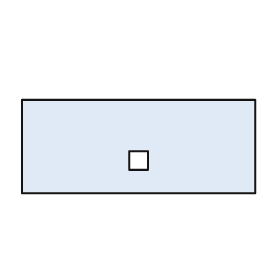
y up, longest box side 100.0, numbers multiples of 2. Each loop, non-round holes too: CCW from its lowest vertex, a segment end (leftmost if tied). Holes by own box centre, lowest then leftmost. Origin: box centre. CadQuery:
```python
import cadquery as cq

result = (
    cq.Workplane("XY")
    .moveTo(-50.0, -20.0)
    .lineTo(50.0, -20.0)
    .lineTo(50.0, 20.0)
    .lineTo(-50.0, 20.0)
    .close()
    .moveTo(-4.0, -10.0)
    .lineTo(4.0, -10.0)
    .lineTo(4.0, -2.0)
    .lineTo(-4.0, -2.0)
    .close()
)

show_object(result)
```